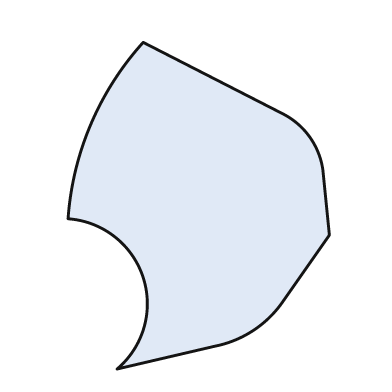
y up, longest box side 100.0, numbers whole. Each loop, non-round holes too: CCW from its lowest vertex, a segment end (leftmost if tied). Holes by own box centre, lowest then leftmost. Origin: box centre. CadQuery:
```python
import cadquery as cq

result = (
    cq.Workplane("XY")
    .moveTo(-25.0, -50.0)
    .lineTo(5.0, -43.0)
    .threePointArc((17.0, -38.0), (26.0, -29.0))
    .lineTo(40.0, -9.0)
    .lineTo(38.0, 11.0)
    .threePointArc((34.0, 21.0), (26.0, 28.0))
    .lineTo(-17.0, 50.0)
    .threePointArc((-33.0, 25.0), (-40.0, -4.0))
    .threePointArc((-17.0, -22.0), (-25.0, -50.0))
    .close()
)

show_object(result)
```